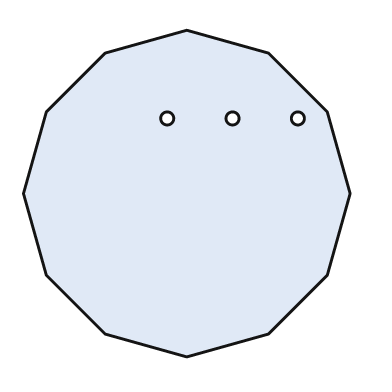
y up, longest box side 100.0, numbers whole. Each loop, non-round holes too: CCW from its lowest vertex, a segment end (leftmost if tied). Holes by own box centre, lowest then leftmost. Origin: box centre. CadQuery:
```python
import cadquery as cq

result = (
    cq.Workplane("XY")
    .moveTo(0.0, -50.0)
    .lineTo(25.0, -43.0)
    .lineTo(43.0, -25.0)
    .lineTo(50.0, 0.0)
    .lineTo(43.0, 25.0)
    .lineTo(25.0, 43.0)
    .lineTo(0.0, 50.0)
    .lineTo(-25.0, 43.0)
    .lineTo(-43.0, 25.0)
    .lineTo(-50.0, 0.0)
    .lineTo(-43.0, -25.0)
    .lineTo(-25.0, -43.0)
    .close()
    .moveTo(-6.0, 23.0)
    .circle(2.0)
    .moveTo(14.0, 23.0)
    .circle(2.0)
    .moveTo(34.0, 23.0)
    .circle(2.0)
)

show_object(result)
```